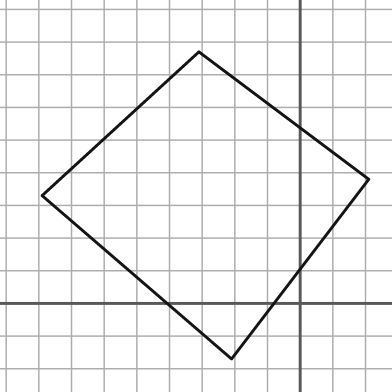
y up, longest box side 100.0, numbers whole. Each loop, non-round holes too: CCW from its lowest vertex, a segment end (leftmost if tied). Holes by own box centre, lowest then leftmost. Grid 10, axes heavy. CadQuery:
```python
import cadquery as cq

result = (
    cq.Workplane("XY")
    .moveTo(-21.0, -17.0)
    .lineTo(21.0, 38.0)
    .lineTo(-31.0, 77.0)
    .lineTo(-79.0, 33.0)
    .close()
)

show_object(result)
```